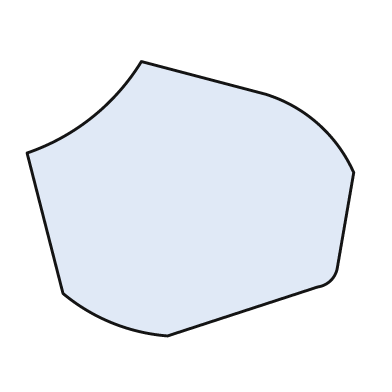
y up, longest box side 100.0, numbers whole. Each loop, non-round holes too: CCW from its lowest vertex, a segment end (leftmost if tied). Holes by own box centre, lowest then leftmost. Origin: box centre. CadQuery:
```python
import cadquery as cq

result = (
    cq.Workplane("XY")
    .moveTo(-7.0, -42.0)
    .lineTo(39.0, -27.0)
    .threePointArc((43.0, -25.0), (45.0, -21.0))
    .lineTo(50.0, 8.0)
    .threePointArc((39.0, 23.0), (23.0, 32.0))
    .lineTo(-15.0, 42.0)
    .threePointArc((-30.0, 25.0), (-50.0, 14.0))
    .lineTo(-39.0, -29.0)
    .threePointArc((-24.0, -38.0), (-7.0, -42.0))
    .close()
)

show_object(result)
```